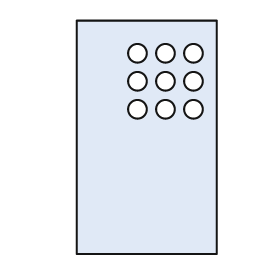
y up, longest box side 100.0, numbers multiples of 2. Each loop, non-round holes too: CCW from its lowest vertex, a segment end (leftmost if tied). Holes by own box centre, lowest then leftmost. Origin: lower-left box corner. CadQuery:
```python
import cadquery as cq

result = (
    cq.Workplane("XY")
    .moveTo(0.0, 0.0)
    .lineTo(60.0, 0.0)
    .lineTo(60.0, 100.0)
    .lineTo(0.0, 100.0)
    .close()
    .moveTo(26.0, 62.0)
    .circle(4.0)
    .moveTo(38.0, 62.0)
    .circle(4.0)
    .moveTo(50.0, 62.0)
    .circle(4.0)
    .moveTo(26.0, 74.0)
    .circle(4.0)
    .moveTo(38.0, 74.0)
    .circle(4.0)
    .moveTo(50.0, 74.0)
    .circle(4.0)
    .moveTo(26.0, 86.0)
    .circle(4.0)
    .moveTo(38.0, 86.0)
    .circle(4.0)
    .moveTo(50.0, 86.0)
    .circle(4.0)
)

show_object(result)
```